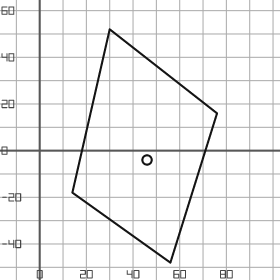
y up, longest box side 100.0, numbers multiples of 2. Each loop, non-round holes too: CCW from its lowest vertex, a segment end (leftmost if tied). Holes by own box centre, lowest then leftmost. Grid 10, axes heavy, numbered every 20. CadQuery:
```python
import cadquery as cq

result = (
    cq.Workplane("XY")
    .moveTo(56.0, -48.0)
    .lineTo(76.0, 16.0)
    .lineTo(30.0, 52.0)
    .lineTo(14.0, -18.0)
    .close()
    .moveTo(46.0, -4.0)
    .circle(2.0)
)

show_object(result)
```